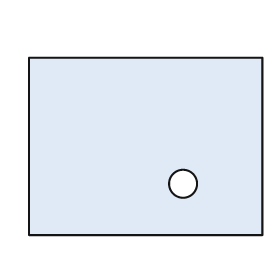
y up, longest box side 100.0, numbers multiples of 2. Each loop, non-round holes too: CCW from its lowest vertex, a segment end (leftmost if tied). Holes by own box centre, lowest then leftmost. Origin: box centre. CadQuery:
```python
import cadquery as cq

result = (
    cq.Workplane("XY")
    .moveTo(-50.0, -38.0)
    .lineTo(50.0, -38.0)
    .lineTo(50.0, 38.0)
    .lineTo(-50.0, 38.0)
    .close()
    .moveTo(16.0, -16.0)
    .circle(6.0)
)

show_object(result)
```